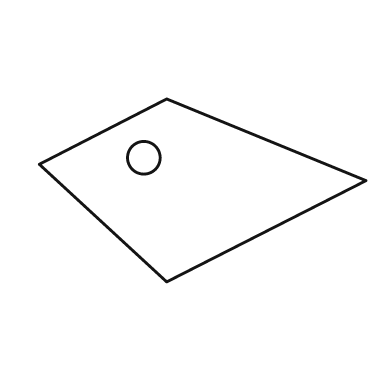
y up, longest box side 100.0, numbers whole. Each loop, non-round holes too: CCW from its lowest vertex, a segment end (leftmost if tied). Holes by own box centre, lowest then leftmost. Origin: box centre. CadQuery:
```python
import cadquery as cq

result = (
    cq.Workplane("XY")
    .moveTo(-11.0, -28.0)
    .lineTo(50.0, 3.0)
    .lineTo(-11.0, 28.0)
    .lineTo(-50.0, 8.0)
    .close()
    .moveTo(-18.0, 10.0)
    .circle(5.0)
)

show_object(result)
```